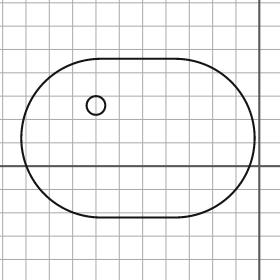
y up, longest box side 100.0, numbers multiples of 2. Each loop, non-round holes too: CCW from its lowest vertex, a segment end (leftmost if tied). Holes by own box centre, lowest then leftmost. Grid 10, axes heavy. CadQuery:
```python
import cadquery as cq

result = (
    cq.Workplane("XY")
    .moveTo(-68.0, -22.0)
    .lineTo(-36.0, -22.0)
    .threePointArc((-2.0, 12.0), (-36.0, 46.0))
    .lineTo(-68.0, 46.0)
    .threePointArc((-102.0, 12.0), (-68.0, -22.0))
    .close()
    .moveTo(-70.0, 26.0)
    .circle(4.0)
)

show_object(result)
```